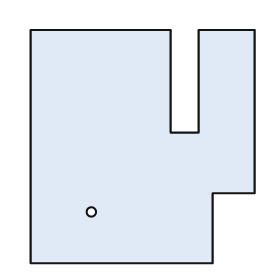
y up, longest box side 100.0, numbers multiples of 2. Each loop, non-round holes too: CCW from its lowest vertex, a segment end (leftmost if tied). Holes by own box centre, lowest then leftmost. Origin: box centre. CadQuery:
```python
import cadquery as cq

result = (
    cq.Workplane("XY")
    .moveTo(-48.0, -50.0)
    .lineTo(30.0, -50.0)
    .lineTo(30.0, -20.0)
    .lineTo(48.0, -20.0)
    .lineTo(48.0, 50.0)
    .lineTo(24.0, 50.0)
    .lineTo(24.0, 6.0)
    .lineTo(12.0, 6.0)
    .lineTo(12.0, 50.0)
    .lineTo(-48.0, 50.0)
    .close()
    .moveTo(-22.0, -28.0)
    .circle(2.0)
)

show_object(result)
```